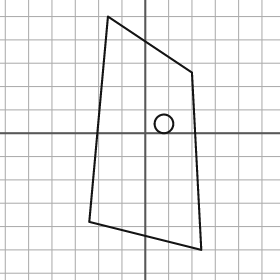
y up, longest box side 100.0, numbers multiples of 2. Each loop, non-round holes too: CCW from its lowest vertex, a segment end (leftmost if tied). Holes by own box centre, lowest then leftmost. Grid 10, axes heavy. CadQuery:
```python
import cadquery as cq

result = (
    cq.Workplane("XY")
    .moveTo(24.0, -50.0)
    .lineTo(20.0, 26.0)
    .lineTo(-16.0, 50.0)
    .lineTo(-24.0, -38.0)
    .close()
    .moveTo(8.0, 4.0)
    .circle(4.0)
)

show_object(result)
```